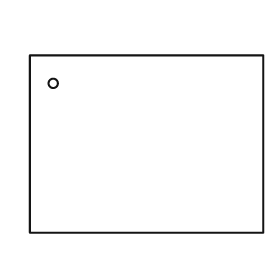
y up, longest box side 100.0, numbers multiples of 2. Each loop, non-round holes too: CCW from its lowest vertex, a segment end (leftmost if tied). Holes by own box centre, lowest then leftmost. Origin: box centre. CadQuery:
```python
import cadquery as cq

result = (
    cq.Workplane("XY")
    .moveTo(-50.0, -38.0)
    .lineTo(50.0, -38.0)
    .lineTo(50.0, 38.0)
    .lineTo(-50.0, 38.0)
    .close()
    .moveTo(-40.0, 26.0)
    .circle(2.0)
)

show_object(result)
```